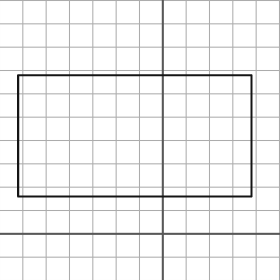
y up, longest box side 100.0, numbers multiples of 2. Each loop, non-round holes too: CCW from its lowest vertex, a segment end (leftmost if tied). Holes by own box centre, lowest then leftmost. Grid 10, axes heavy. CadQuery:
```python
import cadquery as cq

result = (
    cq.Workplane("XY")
    .moveTo(-62.0, 16.0)
    .lineTo(38.0, 16.0)
    .lineTo(38.0, 68.0)
    .lineTo(-62.0, 68.0)
    .close()
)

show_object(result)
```